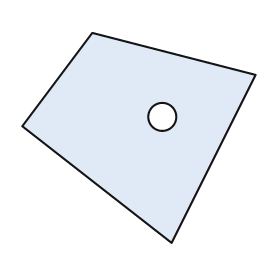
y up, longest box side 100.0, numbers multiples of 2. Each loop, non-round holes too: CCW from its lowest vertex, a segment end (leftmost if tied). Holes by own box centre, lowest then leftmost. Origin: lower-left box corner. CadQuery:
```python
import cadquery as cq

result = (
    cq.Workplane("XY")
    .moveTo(64.0, 0.0)
    .lineTo(100.0, 72.0)
    .lineTo(30.0, 90.0)
    .lineTo(0.0, 50.0)
    .close()
    .moveTo(60.0, 54.0)
    .circle(6.0)
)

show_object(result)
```